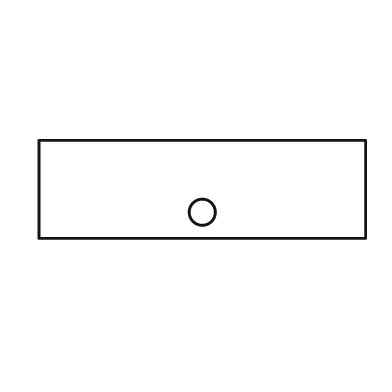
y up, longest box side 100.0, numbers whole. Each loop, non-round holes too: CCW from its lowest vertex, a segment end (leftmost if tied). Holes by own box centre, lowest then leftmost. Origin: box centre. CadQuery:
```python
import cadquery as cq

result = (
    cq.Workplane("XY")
    .moveTo(-50.0, -15.0)
    .lineTo(50.0, -15.0)
    .lineTo(50.0, 15.0)
    .lineTo(-50.0, 15.0)
    .close()
    .moveTo(0.0, -7.0)
    .circle(4.0)
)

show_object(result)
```